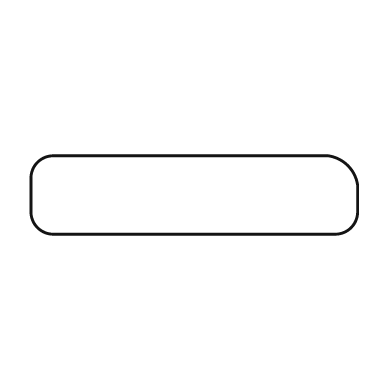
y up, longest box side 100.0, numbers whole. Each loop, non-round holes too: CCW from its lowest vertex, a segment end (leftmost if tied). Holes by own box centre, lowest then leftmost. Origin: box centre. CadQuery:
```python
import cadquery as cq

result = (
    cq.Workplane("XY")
    .moveTo(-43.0, -12.0)
    .lineTo(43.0, -12.0)
    .threePointArc((48.0, -10.0), (50.0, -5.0))
    .lineTo(50.0, 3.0)
    .threePointArc((47.0, 9.0), (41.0, 12.0))
    .lineTo(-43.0, 12.0)
    .threePointArc((-48.0, 10.0), (-50.0, 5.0))
    .lineTo(-50.0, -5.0)
    .threePointArc((-48.0, -10.0), (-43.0, -12.0))
    .close()
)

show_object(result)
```